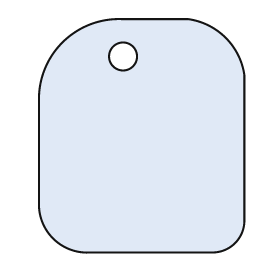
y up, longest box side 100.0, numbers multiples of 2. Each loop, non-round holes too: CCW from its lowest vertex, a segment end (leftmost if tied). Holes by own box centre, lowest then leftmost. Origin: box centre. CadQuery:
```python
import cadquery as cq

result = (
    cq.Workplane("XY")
    .moveTo(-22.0, -50.0)
    .lineTo(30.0, -50.0)
    .threePointArc((40.0, -46.0), (44.0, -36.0))
    .lineTo(44.0, 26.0)
    .threePointArc((36.0, 42.0), (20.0, 50.0))
    .lineTo(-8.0, 50.0)
    .threePointArc((-34.0, 40.0), (-44.0, 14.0))
    .lineTo(-44.0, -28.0)
    .threePointArc((-38.0, -44.0), (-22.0, -50.0))
    .close()
    .moveTo(-8.0, 34.0)
    .circle(6.0)
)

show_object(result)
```